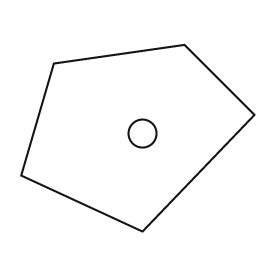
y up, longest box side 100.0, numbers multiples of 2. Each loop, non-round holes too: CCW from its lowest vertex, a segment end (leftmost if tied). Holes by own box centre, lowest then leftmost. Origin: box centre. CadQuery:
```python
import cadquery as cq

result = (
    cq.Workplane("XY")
    .moveTo(2.0, -40.0)
    .lineTo(50.0, 10.0)
    .lineTo(20.0, 40.0)
    .lineTo(-36.0, 32.0)
    .lineTo(-50.0, -16.0)
    .close()
    .moveTo(2.0, 2.0)
    .circle(6.0)
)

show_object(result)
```